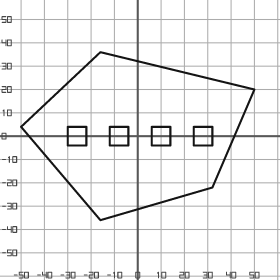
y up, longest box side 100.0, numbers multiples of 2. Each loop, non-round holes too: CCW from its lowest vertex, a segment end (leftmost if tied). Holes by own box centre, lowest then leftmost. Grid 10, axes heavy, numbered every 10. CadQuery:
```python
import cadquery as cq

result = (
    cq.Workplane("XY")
    .moveTo(-16.0, -36.0)
    .lineTo(32.0, -22.0)
    .lineTo(50.0, 20.0)
    .lineTo(-16.0, 36.0)
    .lineTo(-50.0, 4.0)
    .close()
    .moveTo(-30.0, -4.0)
    .lineTo(-22.0, -4.0)
    .lineTo(-22.0, 4.0)
    .lineTo(-30.0, 4.0)
    .close()
    .moveTo(-12.0, -4.0)
    .lineTo(-4.0, -4.0)
    .lineTo(-4.0, 4.0)
    .lineTo(-12.0, 4.0)
    .close()
    .moveTo(6.0, -4.0)
    .lineTo(14.0, -4.0)
    .lineTo(14.0, 4.0)
    .lineTo(6.0, 4.0)
    .close()
    .moveTo(24.0, -4.0)
    .lineTo(32.0, -4.0)
    .lineTo(32.0, 4.0)
    .lineTo(24.0, 4.0)
    .close()
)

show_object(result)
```